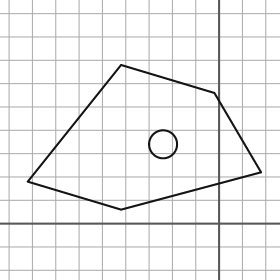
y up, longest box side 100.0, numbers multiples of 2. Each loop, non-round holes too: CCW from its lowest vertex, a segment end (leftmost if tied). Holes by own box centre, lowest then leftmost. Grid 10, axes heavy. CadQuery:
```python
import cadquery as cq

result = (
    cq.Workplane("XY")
    .moveTo(-42.0, 6.0)
    .lineTo(18.0, 22.0)
    .lineTo(-2.0, 56.0)
    .lineTo(-42.0, 68.0)
    .lineTo(-82.0, 18.0)
    .close()
    .moveTo(-24.0, 34.0)
    .circle(6.0)
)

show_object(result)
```